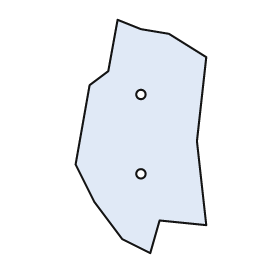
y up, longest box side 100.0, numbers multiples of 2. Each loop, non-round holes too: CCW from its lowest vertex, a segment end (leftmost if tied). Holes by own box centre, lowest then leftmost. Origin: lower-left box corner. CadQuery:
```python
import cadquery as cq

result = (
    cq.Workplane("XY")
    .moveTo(32.0, 0.0)
    .lineTo(36.0, 14.0)
    .lineTo(56.0, 12.0)
    .lineTo(52.0, 48.0)
    .lineTo(56.0, 84.0)
    .lineTo(40.0, 94.0)
    .lineTo(28.0, 96.0)
    .lineTo(18.0, 100.0)
    .lineTo(14.0, 78.0)
    .lineTo(6.0, 72.0)
    .lineTo(0.0, 38.0)
    .lineTo(8.0, 22.0)
    .lineTo(20.0, 6.0)
    .close()
    .moveTo(28.0, 34.0)
    .circle(2.0)
    .moveTo(28.0, 68.0)
    .circle(2.0)
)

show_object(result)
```